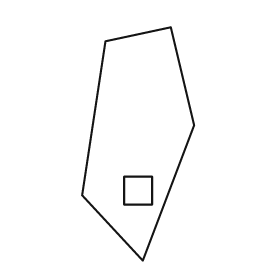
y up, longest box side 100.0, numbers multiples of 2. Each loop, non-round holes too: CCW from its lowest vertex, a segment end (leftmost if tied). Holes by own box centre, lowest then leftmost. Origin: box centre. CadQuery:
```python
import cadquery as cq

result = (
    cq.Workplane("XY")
    .moveTo(2.0, -50.0)
    .lineTo(24.0, 8.0)
    .lineTo(14.0, 50.0)
    .lineTo(-14.0, 44.0)
    .lineTo(-24.0, -22.0)
    .close()
    .moveTo(-6.0, -26.0)
    .lineTo(6.0, -26.0)
    .lineTo(6.0, -14.0)
    .lineTo(-6.0, -14.0)
    .close()
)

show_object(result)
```